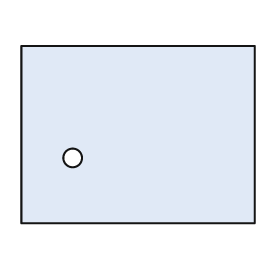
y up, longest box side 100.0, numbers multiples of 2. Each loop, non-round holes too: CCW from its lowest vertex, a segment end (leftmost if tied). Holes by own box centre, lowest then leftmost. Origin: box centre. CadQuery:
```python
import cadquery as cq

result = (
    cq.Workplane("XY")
    .moveTo(-50.0, -38.0)
    .lineTo(50.0, -38.0)
    .lineTo(50.0, 38.0)
    .lineTo(-50.0, 38.0)
    .close()
    .moveTo(-28.0, -10.0)
    .circle(4.0)
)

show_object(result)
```